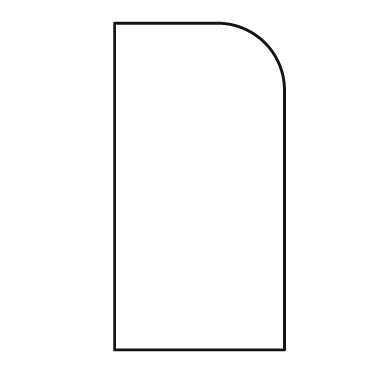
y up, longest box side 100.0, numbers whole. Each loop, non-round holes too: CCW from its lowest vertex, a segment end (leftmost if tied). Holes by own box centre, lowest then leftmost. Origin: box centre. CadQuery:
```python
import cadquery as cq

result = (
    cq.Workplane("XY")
    .moveTo(-26.0, -50.0)
    .lineTo(26.0, -50.0)
    .lineTo(26.0, 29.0)
    .threePointArc((20.0, 44.0), (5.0, 50.0))
    .lineTo(-26.0, 50.0)
    .close()
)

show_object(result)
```